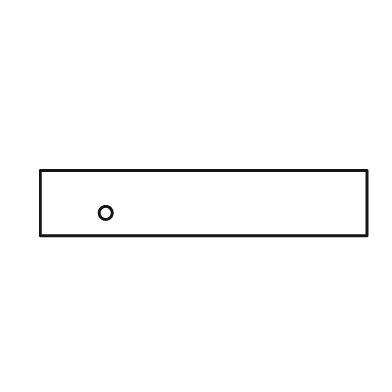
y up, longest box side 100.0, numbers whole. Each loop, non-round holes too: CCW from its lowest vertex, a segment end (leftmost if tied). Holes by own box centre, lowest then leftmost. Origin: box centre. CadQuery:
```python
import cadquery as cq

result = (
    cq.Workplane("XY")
    .moveTo(-50.0, -10.0)
    .lineTo(50.0, -10.0)
    .lineTo(50.0, 10.0)
    .lineTo(-50.0, 10.0)
    .close()
    .moveTo(-30.0, -3.0)
    .circle(2.0)
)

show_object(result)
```